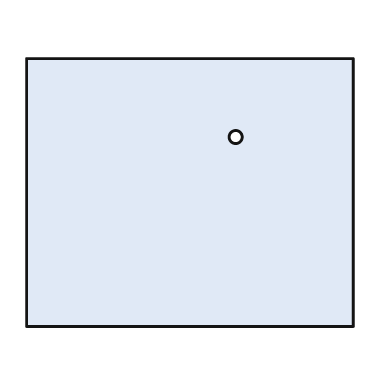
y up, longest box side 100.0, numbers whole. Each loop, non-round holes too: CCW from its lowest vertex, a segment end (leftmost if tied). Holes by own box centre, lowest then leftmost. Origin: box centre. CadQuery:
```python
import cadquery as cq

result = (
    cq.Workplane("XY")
    .moveTo(-50.0, -41.0)
    .lineTo(50.0, -41.0)
    .lineTo(50.0, 41.0)
    .lineTo(-50.0, 41.0)
    .close()
    .moveTo(14.0, 17.0)
    .circle(2.0)
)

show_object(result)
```